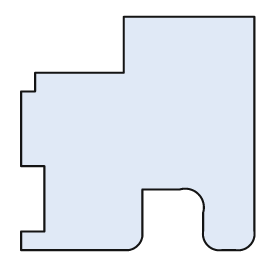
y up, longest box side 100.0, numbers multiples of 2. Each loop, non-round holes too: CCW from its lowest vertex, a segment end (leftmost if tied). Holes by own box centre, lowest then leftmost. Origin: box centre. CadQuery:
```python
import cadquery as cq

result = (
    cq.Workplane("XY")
    .moveTo(-50.0, -50.0)
    .lineTo(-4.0, -50.0)
    .threePointArc((0.0, -48.0), (2.0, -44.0))
    .lineTo(2.0, -24.0)
    .lineTo(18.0, -24.0)
    .threePointArc((26.0, -26.0), (28.0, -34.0))
    .lineTo(28.0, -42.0)
    .threePointArc((30.0, -48.0), (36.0, -50.0))
    .lineTo(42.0, -50.0)
    .threePointArc((48.0, -48.0), (50.0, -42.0))
    .lineTo(50.0, 50.0)
    .lineTo(-6.0, 50.0)
    .lineTo(-6.0, 26.0)
    .lineTo(-44.0, 26.0)
    .lineTo(-44.0, 18.0)
    .lineTo(-50.0, 18.0)
    .lineTo(-50.0, -14.0)
    .lineTo(-40.0, -14.0)
    .lineTo(-40.0, -42.0)
    .lineTo(-50.0, -42.0)
    .close()
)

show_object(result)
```